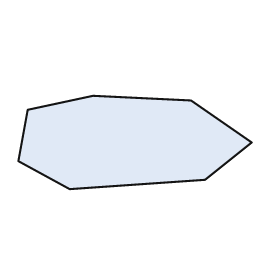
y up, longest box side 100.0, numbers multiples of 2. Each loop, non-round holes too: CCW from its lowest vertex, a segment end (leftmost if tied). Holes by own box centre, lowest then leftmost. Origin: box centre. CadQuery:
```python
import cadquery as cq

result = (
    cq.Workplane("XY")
    .moveTo(-28.0, -20.0)
    .lineTo(30.0, -16.0)
    .lineTo(50.0, 0.0)
    .lineTo(24.0, 18.0)
    .lineTo(-18.0, 20.0)
    .lineTo(-46.0, 14.0)
    .lineTo(-50.0, -8.0)
    .close()
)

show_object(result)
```